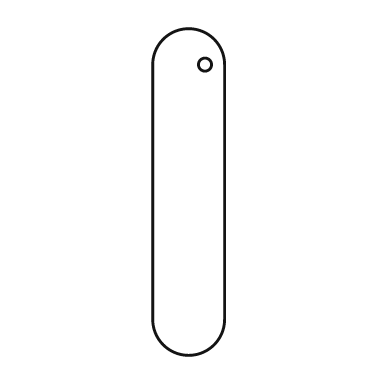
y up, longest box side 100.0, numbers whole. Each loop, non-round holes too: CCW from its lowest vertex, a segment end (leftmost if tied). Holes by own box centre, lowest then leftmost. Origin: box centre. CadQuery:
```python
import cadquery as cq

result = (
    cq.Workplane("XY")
    .moveTo(-11.0, -39.0)
    .threePointArc((0.0, -50.0), (11.0, -39.0))
    .lineTo(11.0, 39.0)
    .threePointArc((0.0, 50.0), (-11.0, 39.0))
    .close()
    .moveTo(5.0, 39.0)
    .circle(2.0)
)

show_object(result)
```